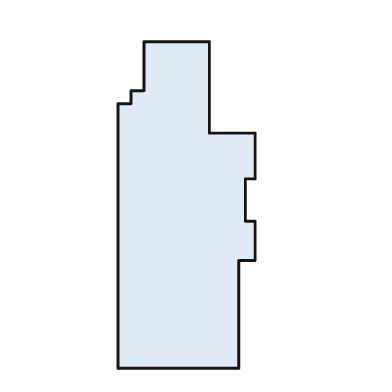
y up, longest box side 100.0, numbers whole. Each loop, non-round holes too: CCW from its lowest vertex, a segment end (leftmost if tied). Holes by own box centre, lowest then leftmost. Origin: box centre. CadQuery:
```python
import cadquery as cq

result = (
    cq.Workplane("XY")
    .moveTo(-21.0, -50.0)
    .lineTo(16.0, -50.0)
    .lineTo(16.0, -17.0)
    .lineTo(21.0, -17.0)
    .lineTo(21.0, -5.0)
    .lineTo(18.0, -5.0)
    .lineTo(18.0, 8.0)
    .lineTo(21.0, 8.0)
    .lineTo(21.0, 22.0)
    .lineTo(7.0, 22.0)
    .lineTo(7.0, 50.0)
    .lineTo(-13.0, 50.0)
    .lineTo(-13.0, 35.0)
    .lineTo(-17.0, 35.0)
    .lineTo(-17.0, 31.0)
    .lineTo(-21.0, 31.0)
    .close()
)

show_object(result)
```